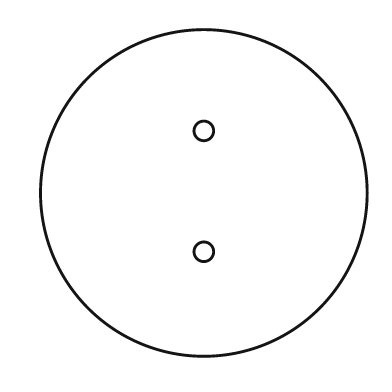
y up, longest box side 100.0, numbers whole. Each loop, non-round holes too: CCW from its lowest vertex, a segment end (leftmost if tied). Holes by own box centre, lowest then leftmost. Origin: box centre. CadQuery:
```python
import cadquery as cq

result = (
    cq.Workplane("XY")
    .moveTo(0.0, 0.0)
    .circle(50.0)
    .moveTo(0.0, -18.0)
    .circle(3.0)
    .moveTo(0.0, 19.0)
    .circle(3.0)
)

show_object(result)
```